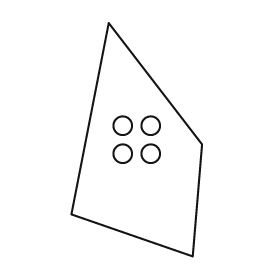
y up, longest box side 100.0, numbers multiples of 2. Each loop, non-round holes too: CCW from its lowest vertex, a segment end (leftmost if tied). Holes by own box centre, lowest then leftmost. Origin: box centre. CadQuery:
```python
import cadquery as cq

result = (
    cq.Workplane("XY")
    .moveTo(24.0, -50.0)
    .lineTo(28.0, -2.0)
    .lineTo(-12.0, 50.0)
    .lineTo(-28.0, -32.0)
    .close()
    .moveTo(-6.0, -6.0)
    .circle(4.0)
    .moveTo(6.0, -6.0)
    .circle(4.0)
    .moveTo(-6.0, 6.0)
    .circle(4.0)
    .moveTo(6.0, 6.0)
    .circle(4.0)
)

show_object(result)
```